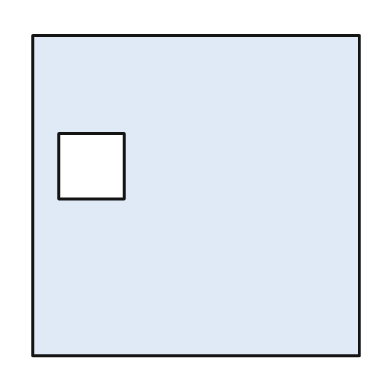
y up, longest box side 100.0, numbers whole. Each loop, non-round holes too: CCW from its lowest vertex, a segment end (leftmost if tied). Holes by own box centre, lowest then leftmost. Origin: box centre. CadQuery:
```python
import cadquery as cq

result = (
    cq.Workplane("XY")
    .moveTo(-50.0, -49.0)
    .lineTo(50.0, -49.0)
    .lineTo(50.0, 49.0)
    .lineTo(-50.0, 49.0)
    .close()
    .moveTo(-42.0, -1.0)
    .lineTo(-22.0, -1.0)
    .lineTo(-22.0, 19.0)
    .lineTo(-42.0, 19.0)
    .close()
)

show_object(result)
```